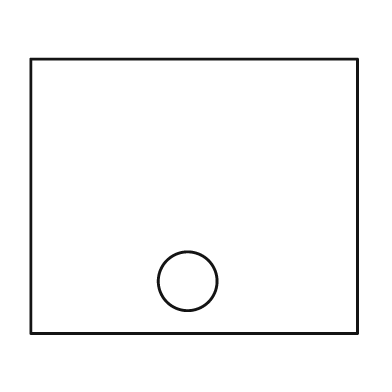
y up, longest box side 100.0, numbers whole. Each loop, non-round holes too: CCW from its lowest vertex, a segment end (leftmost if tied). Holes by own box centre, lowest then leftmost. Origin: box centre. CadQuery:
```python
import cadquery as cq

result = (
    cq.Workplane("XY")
    .moveTo(-50.0, -42.0)
    .lineTo(50.0, -42.0)
    .lineTo(50.0, 42.0)
    .lineTo(-50.0, 42.0)
    .close()
    .moveTo(-2.0, -26.0)
    .circle(9.0)
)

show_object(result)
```